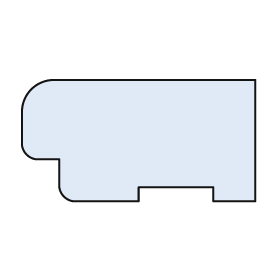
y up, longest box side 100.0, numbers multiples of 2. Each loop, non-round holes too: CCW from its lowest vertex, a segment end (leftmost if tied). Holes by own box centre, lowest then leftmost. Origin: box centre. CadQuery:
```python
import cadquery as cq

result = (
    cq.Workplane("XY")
    .moveTo(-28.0, -26.0)
    .lineTo(0.0, -26.0)
    .lineTo(0.0, -20.0)
    .lineTo(32.0, -20.0)
    .lineTo(32.0, -26.0)
    .lineTo(50.0, -26.0)
    .lineTo(50.0, 26.0)
    .lineTo(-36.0, 26.0)
    .threePointArc((-46.0, 22.0), (-50.0, 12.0))
    .lineTo(-50.0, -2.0)
    .threePointArc((-48.0, -6.0), (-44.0, -8.0))
    .lineTo(-34.0, -8.0)
    .lineTo(-34.0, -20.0)
    .threePointArc((-32.0, -24.0), (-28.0, -26.0))
    .close()
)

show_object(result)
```